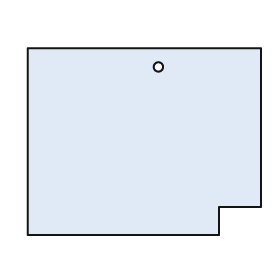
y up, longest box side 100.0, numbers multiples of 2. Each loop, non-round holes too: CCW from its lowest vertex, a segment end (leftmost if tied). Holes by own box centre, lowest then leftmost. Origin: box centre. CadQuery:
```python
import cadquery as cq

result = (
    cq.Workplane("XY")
    .moveTo(-50.0, -40.0)
    .lineTo(32.0, -40.0)
    .lineTo(32.0, -28.0)
    .lineTo(50.0, -28.0)
    .lineTo(50.0, 40.0)
    .lineTo(-50.0, 40.0)
    .close()
    .moveTo(6.0, 32.0)
    .circle(2.0)
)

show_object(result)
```